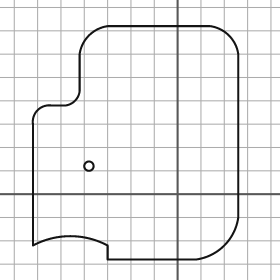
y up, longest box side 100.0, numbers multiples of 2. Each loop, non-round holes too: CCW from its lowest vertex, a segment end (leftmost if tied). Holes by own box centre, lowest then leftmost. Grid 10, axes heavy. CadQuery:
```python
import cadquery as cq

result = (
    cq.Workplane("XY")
    .moveTo(-30.0, -28.0)
    .lineTo(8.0, -28.0)
    .threePointArc((20.0, -22.0), (26.0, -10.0))
    .lineTo(26.0, 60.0)
    .threePointArc((22.0, 68.0), (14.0, 72.0))
    .lineTo(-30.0, 72.0)
    .threePointArc((-38.0, 68.0), (-42.0, 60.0))
    .lineTo(-42.0, 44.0)
    .threePointArc((-44.0, 40.0), (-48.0, 38.0))
    .lineTo(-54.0, 38.0)
    .threePointArc((-60.0, 36.0), (-62.0, 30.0))
    .lineTo(-62.0, -22.0)
    .threePointArc((-46.0, -18.0), (-30.0, -22.0))
    .close()
    .moveTo(-38.0, 12.0)
    .circle(2.0)
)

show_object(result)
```